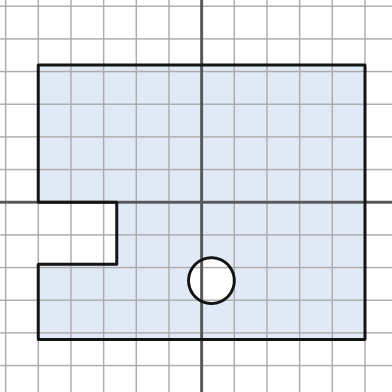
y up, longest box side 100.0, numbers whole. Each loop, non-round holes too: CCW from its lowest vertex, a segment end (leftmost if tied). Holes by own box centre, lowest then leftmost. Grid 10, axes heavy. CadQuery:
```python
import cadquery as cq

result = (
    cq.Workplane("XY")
    .moveTo(-50.0, -42.0)
    .lineTo(50.0, -42.0)
    .lineTo(50.0, 42.0)
    .lineTo(-50.0, 42.0)
    .lineTo(-50.0, 0.0)
    .lineTo(-26.0, 0.0)
    .lineTo(-26.0, -19.0)
    .lineTo(-50.0, -19.0)
    .close()
    .moveTo(3.0, -24.0)
    .circle(7.0)
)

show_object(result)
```